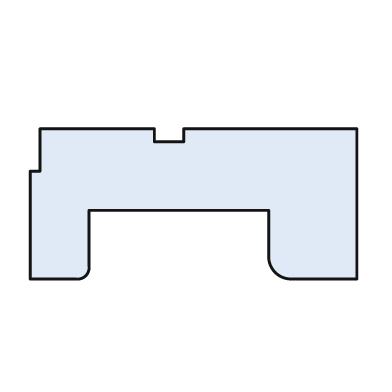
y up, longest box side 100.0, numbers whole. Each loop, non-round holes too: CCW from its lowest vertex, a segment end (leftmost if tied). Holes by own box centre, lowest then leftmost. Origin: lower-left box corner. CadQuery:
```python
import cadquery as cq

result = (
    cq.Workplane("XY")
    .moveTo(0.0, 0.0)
    .lineTo(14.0, 0.0)
    .threePointArc((17.0, 1.0), (18.0, 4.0))
    .lineTo(18.0, 21.0)
    .lineTo(73.0, 21.0)
    .lineTo(73.0, 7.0)
    .threePointArc((75.0, 2.0), (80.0, 0.0))
    .lineTo(100.0, 0.0)
    .lineTo(100.0, 46.0)
    .lineTo(47.0, 46.0)
    .lineTo(47.0, 42.0)
    .lineTo(38.0, 42.0)
    .lineTo(38.0, 46.0)
    .lineTo(3.0, 46.0)
    .lineTo(3.0, 33.0)
    .lineTo(0.0, 33.0)
    .close()
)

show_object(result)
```